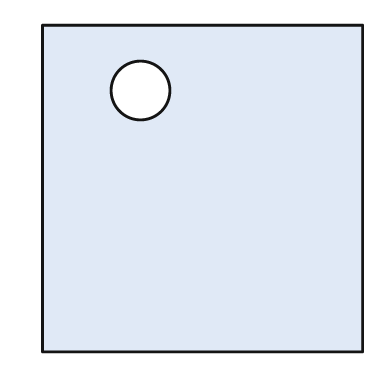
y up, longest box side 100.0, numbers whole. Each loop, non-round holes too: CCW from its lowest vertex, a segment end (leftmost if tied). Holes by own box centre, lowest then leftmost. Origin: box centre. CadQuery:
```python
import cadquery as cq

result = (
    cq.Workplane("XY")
    .moveTo(-49.0, -50.0)
    .lineTo(49.0, -50.0)
    .lineTo(49.0, 50.0)
    .lineTo(-49.0, 50.0)
    .close()
    .moveTo(-19.0, 30.0)
    .circle(9.0)
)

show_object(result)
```